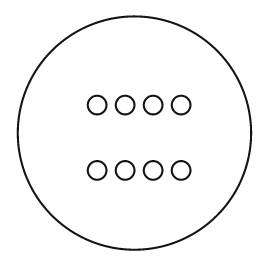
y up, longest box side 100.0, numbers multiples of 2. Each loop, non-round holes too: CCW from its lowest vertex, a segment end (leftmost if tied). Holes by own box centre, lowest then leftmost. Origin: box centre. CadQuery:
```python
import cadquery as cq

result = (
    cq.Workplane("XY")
    .moveTo(0.0, 0.0)
    .circle(50.0)
    .moveTo(-16.0, -16.0)
    .circle(4.0)
    .moveTo(-4.0, -16.0)
    .circle(4.0)
    .moveTo(8.0, -16.0)
    .circle(4.0)
    .moveTo(20.0, -16.0)
    .circle(4.0)
    .moveTo(-16.0, 12.0)
    .circle(4.0)
    .moveTo(-4.0, 12.0)
    .circle(4.0)
    .moveTo(8.0, 12.0)
    .circle(4.0)
    .moveTo(20.0, 12.0)
    .circle(4.0)
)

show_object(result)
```